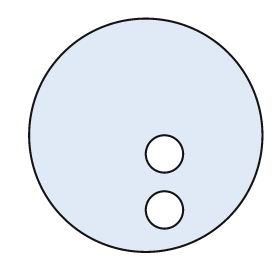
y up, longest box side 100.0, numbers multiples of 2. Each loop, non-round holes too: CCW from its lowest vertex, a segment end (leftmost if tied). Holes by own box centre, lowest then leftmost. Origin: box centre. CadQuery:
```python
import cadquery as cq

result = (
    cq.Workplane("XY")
    .moveTo(0.0, 0.0)
    .circle(50.0)
    .moveTo(8.0, -32.0)
    .circle(8.0)
    .moveTo(8.0, -8.0)
    .circle(8.0)
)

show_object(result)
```